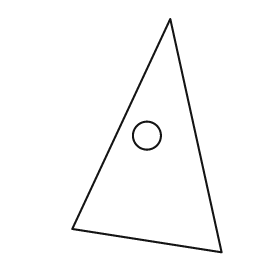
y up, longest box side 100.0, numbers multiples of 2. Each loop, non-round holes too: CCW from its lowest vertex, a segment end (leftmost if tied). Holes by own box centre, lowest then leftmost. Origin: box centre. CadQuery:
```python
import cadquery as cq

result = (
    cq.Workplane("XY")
    .moveTo(32.0, -50.0)
    .lineTo(10.0, 50.0)
    .lineTo(-32.0, -40.0)
    .close()
    .moveTo(0.0, 0.0)
    .circle(6.0)
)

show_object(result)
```